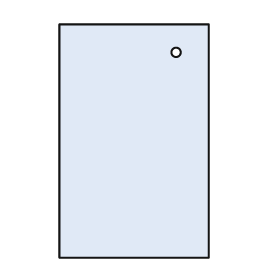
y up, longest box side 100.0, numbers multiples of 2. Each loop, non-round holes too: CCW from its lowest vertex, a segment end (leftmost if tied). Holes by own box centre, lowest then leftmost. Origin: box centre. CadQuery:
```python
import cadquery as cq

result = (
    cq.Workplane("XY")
    .moveTo(-32.0, -50.0)
    .lineTo(32.0, -50.0)
    .lineTo(32.0, 50.0)
    .lineTo(-32.0, 50.0)
    .close()
    .moveTo(18.0, 38.0)
    .circle(2.0)
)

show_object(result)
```